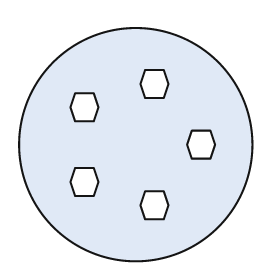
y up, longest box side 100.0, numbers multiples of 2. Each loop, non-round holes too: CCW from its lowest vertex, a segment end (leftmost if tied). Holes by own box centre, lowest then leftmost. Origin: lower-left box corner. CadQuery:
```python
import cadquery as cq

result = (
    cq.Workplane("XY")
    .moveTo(50.0, 50.0)
    .circle(50.0)
    .moveTo(54.0, 18.0)
    .lineTo(62.0, 18.0)
    .lineTo(64.0, 24.0)
    .lineTo(62.0, 30.0)
    .lineTo(54.0, 30.0)
    .lineTo(52.0, 24.0)
    .close()
    .moveTo(24.0, 28.0)
    .lineTo(32.0, 28.0)
    .lineTo(34.0, 34.0)
    .lineTo(32.0, 40.0)
    .lineTo(24.0, 40.0)
    .lineTo(22.0, 34.0)
    .close()
    .moveTo(74.0, 44.0)
    .lineTo(82.0, 44.0)
    .lineTo(84.0, 50.0)
    .lineTo(82.0, 56.0)
    .lineTo(74.0, 56.0)
    .lineTo(72.0, 50.0)
    .close()
    .moveTo(24.0, 60.0)
    .lineTo(32.0, 60.0)
    .lineTo(34.0, 66.0)
    .lineTo(32.0, 72.0)
    .lineTo(24.0, 72.0)
    .lineTo(22.0, 66.0)
    .close()
    .moveTo(54.0, 70.0)
    .lineTo(62.0, 70.0)
    .lineTo(64.0, 76.0)
    .lineTo(62.0, 82.0)
    .lineTo(54.0, 82.0)
    .lineTo(52.0, 76.0)
    .close()
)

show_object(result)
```